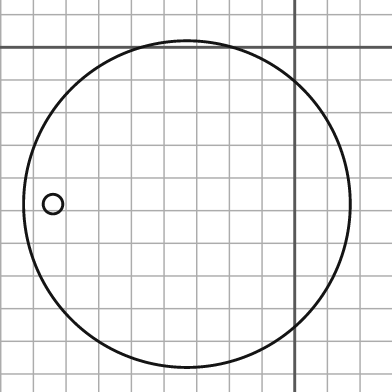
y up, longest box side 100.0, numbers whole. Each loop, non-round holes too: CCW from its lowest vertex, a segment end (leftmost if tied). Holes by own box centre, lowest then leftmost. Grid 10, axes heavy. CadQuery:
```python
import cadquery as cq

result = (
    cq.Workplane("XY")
    .moveTo(-33.0, -48.0)
    .circle(50.0)
    .moveTo(-74.0, -48.0)
    .circle(3.0)
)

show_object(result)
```